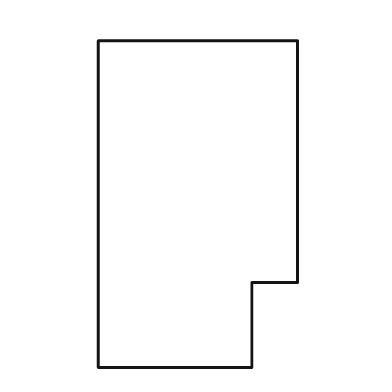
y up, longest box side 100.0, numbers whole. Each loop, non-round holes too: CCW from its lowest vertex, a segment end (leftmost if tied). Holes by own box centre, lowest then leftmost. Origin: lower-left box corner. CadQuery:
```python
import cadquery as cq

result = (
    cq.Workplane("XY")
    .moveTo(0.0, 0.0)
    .lineTo(47.0, 0.0)
    .lineTo(47.0, 26.0)
    .lineTo(61.0, 26.0)
    .lineTo(61.0, 100.0)
    .lineTo(0.0, 100.0)
    .close()
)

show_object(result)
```